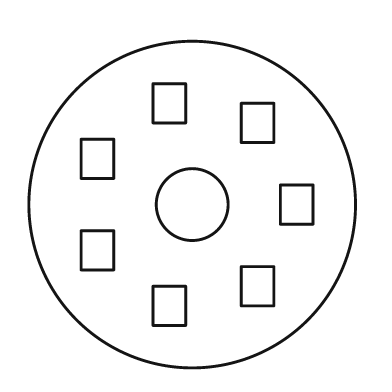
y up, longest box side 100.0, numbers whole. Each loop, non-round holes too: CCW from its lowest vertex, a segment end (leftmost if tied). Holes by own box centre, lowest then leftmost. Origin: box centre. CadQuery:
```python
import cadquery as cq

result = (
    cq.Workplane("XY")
    .moveTo(0.0, 0.0)
    .circle(50.0)
    .moveTo(-12.0, -37.0)
    .lineTo(-2.0, -37.0)
    .lineTo(-2.0, -25.0)
    .lineTo(-12.0, -25.0)
    .close()
    .moveTo(15.0, -31.0)
    .lineTo(25.0, -31.0)
    .lineTo(25.0, -19.0)
    .lineTo(15.0, -19.0)
    .close()
    .moveTo(-34.0, -20.0)
    .lineTo(-24.0, -20.0)
    .lineTo(-24.0, -8.0)
    .lineTo(-34.0, -8.0)
    .close()
    .moveTo(0.0, 0.0)
    .circle(11.0)
    .moveTo(27.0, -6.0)
    .lineTo(37.0, -6.0)
    .lineTo(37.0, 6.0)
    .lineTo(27.0, 6.0)
    .close()
    .moveTo(-34.0, 8.0)
    .lineTo(-24.0, 8.0)
    .lineTo(-24.0, 20.0)
    .lineTo(-34.0, 20.0)
    .close()
    .moveTo(15.0, 19.0)
    .lineTo(25.0, 19.0)
    .lineTo(25.0, 31.0)
    .lineTo(15.0, 31.0)
    .close()
    .moveTo(-12.0, 25.0)
    .lineTo(-2.0, 25.0)
    .lineTo(-2.0, 37.0)
    .lineTo(-12.0, 37.0)
    .close()
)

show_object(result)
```